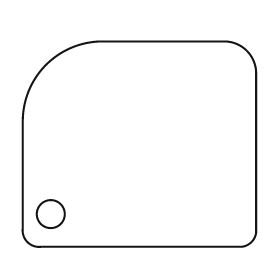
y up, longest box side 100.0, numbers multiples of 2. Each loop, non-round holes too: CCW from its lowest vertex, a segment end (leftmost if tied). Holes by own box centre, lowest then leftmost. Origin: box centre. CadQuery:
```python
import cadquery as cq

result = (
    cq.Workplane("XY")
    .moveTo(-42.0, -44.0)
    .lineTo(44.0, -44.0)
    .threePointArc((48.0, -42.0), (50.0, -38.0))
    .lineTo(50.0, 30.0)
    .threePointArc((46.0, 40.0), (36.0, 44.0))
    .lineTo(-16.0, 44.0)
    .threePointArc((-40.0, 34.0), (-50.0, 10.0))
    .lineTo(-50.0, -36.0)
    .threePointArc((-48.0, -42.0), (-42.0, -44.0))
    .close()
    .moveTo(-38.0, -30.0)
    .circle(6.0)
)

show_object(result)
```